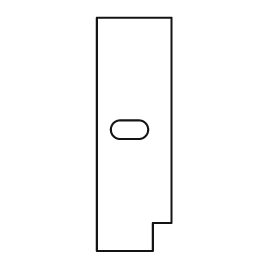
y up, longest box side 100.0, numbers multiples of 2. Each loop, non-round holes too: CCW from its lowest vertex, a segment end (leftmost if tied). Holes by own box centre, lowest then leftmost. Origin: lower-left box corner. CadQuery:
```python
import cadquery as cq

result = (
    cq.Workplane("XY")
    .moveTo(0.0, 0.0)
    .lineTo(24.0, 0.0)
    .lineTo(24.0, 12.0)
    .lineTo(32.0, 12.0)
    .lineTo(32.0, 100.0)
    .lineTo(0.0, 100.0)
    .close()
    .moveTo(10.0, 48.0)
    .lineTo(18.0, 48.0)
    .threePointArc((22.0, 52.0), (18.0, 56.0))
    .lineTo(10.0, 56.0)
    .threePointArc((6.0, 52.0), (10.0, 48.0))
    .close()
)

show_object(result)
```